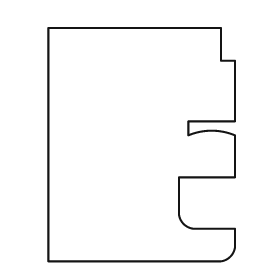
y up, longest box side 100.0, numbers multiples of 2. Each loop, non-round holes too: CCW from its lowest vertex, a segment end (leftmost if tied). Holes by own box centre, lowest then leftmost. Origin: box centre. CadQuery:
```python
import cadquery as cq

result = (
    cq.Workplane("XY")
    .moveTo(-40.0, -50.0)
    .lineTo(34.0, -50.0)
    .threePointArc((38.0, -48.0), (40.0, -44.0))
    .lineTo(40.0, -36.0)
    .lineTo(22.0, -36.0)
    .threePointArc((18.0, -34.0), (16.0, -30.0))
    .lineTo(16.0, -14.0)
    .lineTo(40.0, -14.0)
    .lineTo(40.0, 4.0)
    .threePointArc((30.0, 6.0), (20.0, 4.0))
    .lineTo(20.0, 10.0)
    .lineTo(40.0, 10.0)
    .lineTo(40.0, 36.0)
    .lineTo(34.0, 36.0)
    .lineTo(34.0, 50.0)
    .lineTo(-40.0, 50.0)
    .close()
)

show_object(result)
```